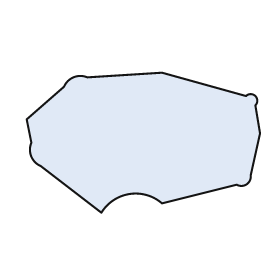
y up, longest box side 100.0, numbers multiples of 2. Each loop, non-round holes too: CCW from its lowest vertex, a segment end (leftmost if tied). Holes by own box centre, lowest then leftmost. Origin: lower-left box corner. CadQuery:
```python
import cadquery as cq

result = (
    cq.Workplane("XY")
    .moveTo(32.0, 0.0)
    .threePointArc((44.0, 8.0), (58.0, 4.0))
    .lineTo(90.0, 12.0)
    .threePointArc((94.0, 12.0), (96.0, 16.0))
    .lineTo(100.0, 34.0)
    .lineTo(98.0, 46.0)
    .threePointArc((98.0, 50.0), (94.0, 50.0))
    .lineTo(58.0, 60.0)
    .lineTo(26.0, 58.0)
    .threePointArc((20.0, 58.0), (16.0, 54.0))
    .lineTo(0.0, 40.0)
    .lineTo(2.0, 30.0)
    .threePointArc((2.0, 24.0), (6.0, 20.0))
    .close()
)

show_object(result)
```